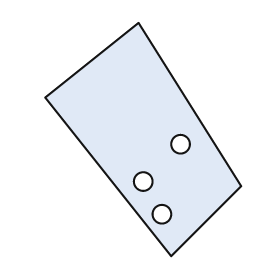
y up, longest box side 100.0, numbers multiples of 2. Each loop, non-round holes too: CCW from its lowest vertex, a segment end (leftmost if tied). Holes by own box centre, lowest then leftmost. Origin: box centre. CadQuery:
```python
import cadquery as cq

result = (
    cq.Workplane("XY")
    .moveTo(12.0, -50.0)
    .lineTo(42.0, -20.0)
    .lineTo(-2.0, 50.0)
    .lineTo(-42.0, 18.0)
    .close()
    .moveTo(8.0, -32.0)
    .circle(4.0)
    .moveTo(0.0, -18.0)
    .circle(4.0)
    .moveTo(16.0, -2.0)
    .circle(4.0)
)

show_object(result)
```